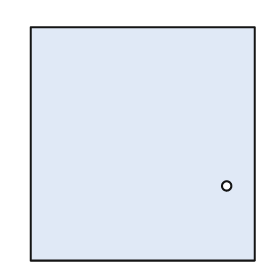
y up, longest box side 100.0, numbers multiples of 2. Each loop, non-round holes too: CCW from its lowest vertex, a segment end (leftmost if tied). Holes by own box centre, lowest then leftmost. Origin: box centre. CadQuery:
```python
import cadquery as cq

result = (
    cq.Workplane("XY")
    .moveTo(-48.0, -50.0)
    .lineTo(48.0, -50.0)
    .lineTo(48.0, 50.0)
    .lineTo(-48.0, 50.0)
    .close()
    .moveTo(36.0, -18.0)
    .circle(2.0)
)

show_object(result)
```